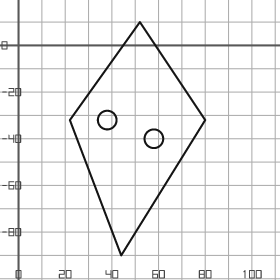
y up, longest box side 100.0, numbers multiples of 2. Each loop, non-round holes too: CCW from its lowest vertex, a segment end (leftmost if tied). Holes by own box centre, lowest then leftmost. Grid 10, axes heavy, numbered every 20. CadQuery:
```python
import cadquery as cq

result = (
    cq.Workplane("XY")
    .moveTo(44.0, -90.0)
    .lineTo(80.0, -32.0)
    .lineTo(52.0, 10.0)
    .lineTo(22.0, -32.0)
    .close()
    .moveTo(58.0, -40.0)
    .circle(4.0)
    .moveTo(38.0, -32.0)
    .circle(4.0)
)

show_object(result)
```